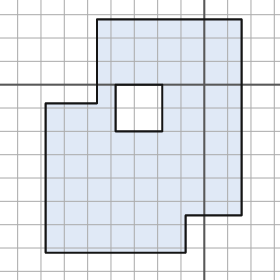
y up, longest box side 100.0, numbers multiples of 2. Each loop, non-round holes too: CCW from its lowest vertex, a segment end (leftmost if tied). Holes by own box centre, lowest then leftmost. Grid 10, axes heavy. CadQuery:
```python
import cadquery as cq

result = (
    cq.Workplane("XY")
    .moveTo(-68.0, -72.0)
    .lineTo(-8.0, -72.0)
    .lineTo(-8.0, -56.0)
    .lineTo(16.0, -56.0)
    .lineTo(16.0, 28.0)
    .lineTo(-46.0, 28.0)
    .lineTo(-46.0, -8.0)
    .lineTo(-68.0, -8.0)
    .close()
    .moveTo(-38.0, -20.0)
    .lineTo(-18.0, -20.0)
    .lineTo(-18.0, 0.0)
    .lineTo(-38.0, 0.0)
    .close()
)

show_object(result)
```